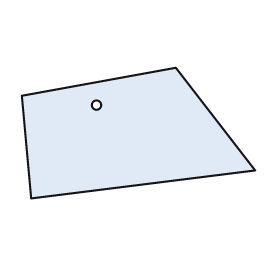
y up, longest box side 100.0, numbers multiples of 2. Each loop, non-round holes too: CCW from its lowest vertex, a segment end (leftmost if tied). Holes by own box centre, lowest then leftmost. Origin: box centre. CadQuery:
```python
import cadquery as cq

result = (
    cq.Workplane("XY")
    .moveTo(-46.0, -28.0)
    .lineTo(50.0, -16.0)
    .lineTo(16.0, 28.0)
    .lineTo(-50.0, 16.0)
    .close()
    .moveTo(-18.0, 12.0)
    .circle(2.0)
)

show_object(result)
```